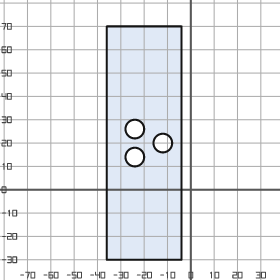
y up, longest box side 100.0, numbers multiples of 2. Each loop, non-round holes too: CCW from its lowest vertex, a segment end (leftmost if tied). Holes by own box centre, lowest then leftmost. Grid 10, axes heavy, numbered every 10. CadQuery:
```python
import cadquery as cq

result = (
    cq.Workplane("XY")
    .moveTo(-36.0, -30.0)
    .lineTo(-4.0, -30.0)
    .lineTo(-4.0, 70.0)
    .lineTo(-36.0, 70.0)
    .close()
    .moveTo(-24.0, 14.0)
    .circle(4.0)
    .moveTo(-12.0, 20.0)
    .circle(4.0)
    .moveTo(-24.0, 26.0)
    .circle(4.0)
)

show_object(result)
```